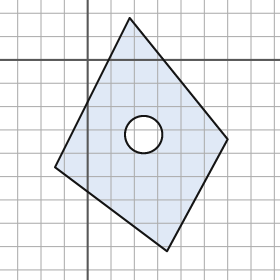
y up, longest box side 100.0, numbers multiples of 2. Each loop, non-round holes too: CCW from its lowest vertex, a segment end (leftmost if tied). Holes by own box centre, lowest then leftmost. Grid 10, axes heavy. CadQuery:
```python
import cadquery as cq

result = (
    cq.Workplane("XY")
    .moveTo(34.0, -82.0)
    .lineTo(60.0, -34.0)
    .lineTo(18.0, 18.0)
    .lineTo(-14.0, -46.0)
    .close()
    .moveTo(24.0, -32.0)
    .circle(8.0)
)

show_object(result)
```